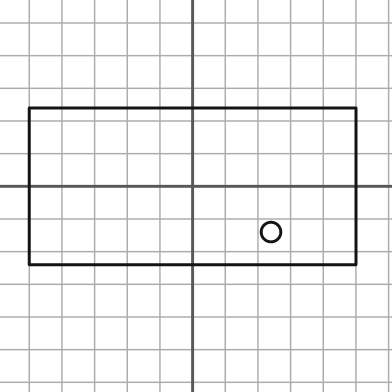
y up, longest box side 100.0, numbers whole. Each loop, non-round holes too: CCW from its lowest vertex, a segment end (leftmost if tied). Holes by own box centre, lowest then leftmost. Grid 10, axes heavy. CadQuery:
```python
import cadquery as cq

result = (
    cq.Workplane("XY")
    .moveTo(-50.0, -24.0)
    .lineTo(50.0, -24.0)
    .lineTo(50.0, 24.0)
    .lineTo(-50.0, 24.0)
    .close()
    .moveTo(24.0, -14.0)
    .circle(3.0)
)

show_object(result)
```